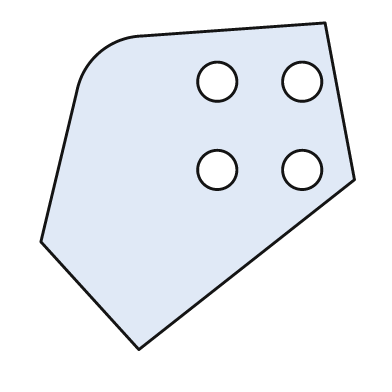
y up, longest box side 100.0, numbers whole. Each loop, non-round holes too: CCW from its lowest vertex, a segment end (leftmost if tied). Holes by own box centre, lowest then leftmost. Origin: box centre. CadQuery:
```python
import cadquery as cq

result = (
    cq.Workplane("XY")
    .moveTo(-18.0, -50.0)
    .lineTo(48.0, 2.0)
    .lineTo(39.0, 50.0)
    .lineTo(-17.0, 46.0)
    .threePointArc((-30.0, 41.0), (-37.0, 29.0))
    .lineTo(-48.0, -17.0)
    .close()
    .moveTo(6.0, 5.0)
    .circle(6.0)
    .moveTo(32.0, 5.0)
    .circle(6.0)
    .moveTo(6.0, 32.0)
    .circle(6.0)
    .moveTo(32.0, 32.0)
    .circle(6.0)
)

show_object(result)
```